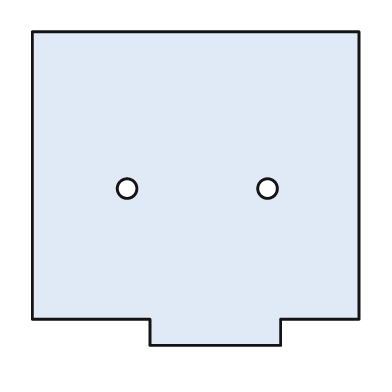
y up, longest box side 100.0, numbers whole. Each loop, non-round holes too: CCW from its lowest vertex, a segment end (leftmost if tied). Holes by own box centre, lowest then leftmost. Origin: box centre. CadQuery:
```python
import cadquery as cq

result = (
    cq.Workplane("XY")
    .moveTo(-14.0, -48.0)
    .lineTo(26.0, -48.0)
    .lineTo(26.0, -40.0)
    .lineTo(50.0, -40.0)
    .lineTo(50.0, 48.0)
    .lineTo(-50.0, 48.0)
    .lineTo(-50.0, -40.0)
    .lineTo(-14.0, -40.0)
    .close()
    .moveTo(-21.0, 0.0)
    .circle(3.0)
    .moveTo(22.0, 0.0)
    .circle(3.0)
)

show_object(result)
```